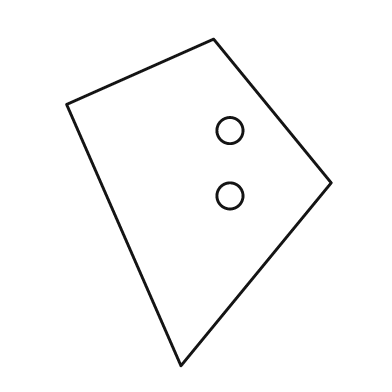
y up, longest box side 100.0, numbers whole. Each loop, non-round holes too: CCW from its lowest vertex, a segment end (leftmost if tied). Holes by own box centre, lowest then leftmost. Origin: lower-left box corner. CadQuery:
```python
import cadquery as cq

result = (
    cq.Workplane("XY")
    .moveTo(35.0, 0.0)
    .lineTo(81.0, 56.0)
    .lineTo(45.0, 100.0)
    .lineTo(0.0, 80.0)
    .close()
    .moveTo(50.0, 52.0)
    .circle(4.0)
    .moveTo(50.0, 72.0)
    .circle(4.0)
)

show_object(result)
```